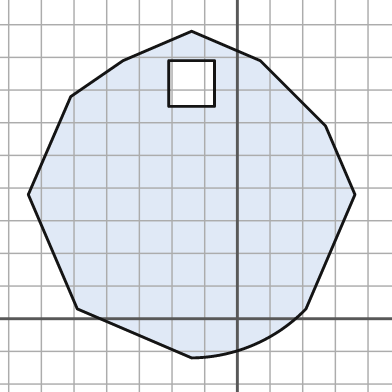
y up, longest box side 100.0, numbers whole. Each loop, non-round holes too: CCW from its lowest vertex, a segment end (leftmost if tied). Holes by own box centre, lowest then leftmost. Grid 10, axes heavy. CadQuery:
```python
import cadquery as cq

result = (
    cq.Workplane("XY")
    .moveTo(-14.0, -12.0)
    .threePointArc((5.0, -8.0), (21.0, 3.0))
    .lineTo(36.0, 38.0)
    .lineTo(27.0, 59.0)
    .lineTo(7.0, 79.0)
    .lineTo(-14.0, 88.0)
    .lineTo(-35.0, 79.0)
    .lineTo(-51.0, 68.0)
    .lineTo(-64.0, 38.0)
    .lineTo(-49.0, 3.0)
    .close()
    .moveTo(-21.0, 65.0)
    .lineTo(-7.0, 65.0)
    .lineTo(-7.0, 79.0)
    .lineTo(-21.0, 79.0)
    .close()
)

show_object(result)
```